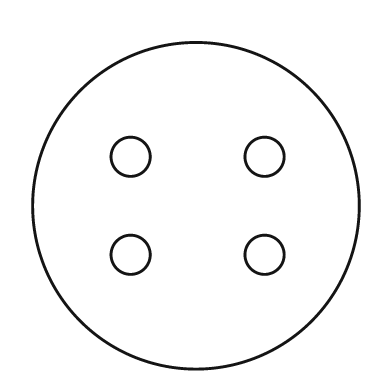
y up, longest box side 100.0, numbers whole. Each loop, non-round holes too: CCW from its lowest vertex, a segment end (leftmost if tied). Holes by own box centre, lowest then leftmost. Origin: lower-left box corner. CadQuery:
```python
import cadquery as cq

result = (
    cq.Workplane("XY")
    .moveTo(50.0, 50.0)
    .circle(50.0)
    .moveTo(30.0, 35.0)
    .circle(6.0)
    .moveTo(71.0, 35.0)
    .circle(6.0)
    .moveTo(30.0, 65.0)
    .circle(6.0)
    .moveTo(71.0, 65.0)
    .circle(6.0)
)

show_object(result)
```